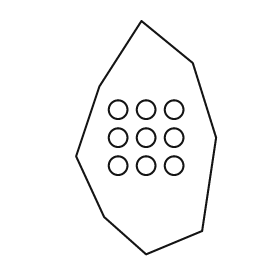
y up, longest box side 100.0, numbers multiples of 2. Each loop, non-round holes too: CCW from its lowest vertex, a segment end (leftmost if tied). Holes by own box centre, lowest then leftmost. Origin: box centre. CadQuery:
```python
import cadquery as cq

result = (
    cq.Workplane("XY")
    .moveTo(0.0, -50.0)
    .lineTo(24.0, -40.0)
    .lineTo(30.0, 0.0)
    .lineTo(20.0, 32.0)
    .lineTo(-2.0, 50.0)
    .lineTo(-20.0, 22.0)
    .lineTo(-30.0, -8.0)
    .lineTo(-18.0, -34.0)
    .close()
    .moveTo(-12.0, -12.0)
    .circle(4.0)
    .moveTo(0.0, -12.0)
    .circle(4.0)
    .moveTo(12.0, -12.0)
    .circle(4.0)
    .moveTo(-12.0, 0.0)
    .circle(4.0)
    .moveTo(0.0, 0.0)
    .circle(4.0)
    .moveTo(12.0, 0.0)
    .circle(4.0)
    .moveTo(-12.0, 12.0)
    .circle(4.0)
    .moveTo(0.0, 12.0)
    .circle(4.0)
    .moveTo(12.0, 12.0)
    .circle(4.0)
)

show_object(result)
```